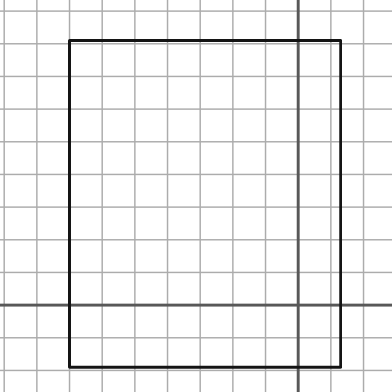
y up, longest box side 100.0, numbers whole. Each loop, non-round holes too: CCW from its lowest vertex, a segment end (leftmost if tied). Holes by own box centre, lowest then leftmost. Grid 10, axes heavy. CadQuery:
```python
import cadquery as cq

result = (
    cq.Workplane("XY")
    .moveTo(-70.0, -19.0)
    .lineTo(13.0, -19.0)
    .lineTo(13.0, 81.0)
    .lineTo(-70.0, 81.0)
    .close()
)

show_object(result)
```